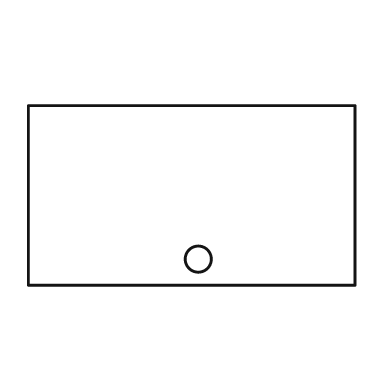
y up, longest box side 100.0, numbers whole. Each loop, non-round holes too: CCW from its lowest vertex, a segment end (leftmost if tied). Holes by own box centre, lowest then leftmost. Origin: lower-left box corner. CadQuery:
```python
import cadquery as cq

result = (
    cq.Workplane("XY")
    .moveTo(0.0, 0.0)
    .lineTo(100.0, 0.0)
    .lineTo(100.0, 55.0)
    .lineTo(0.0, 55.0)
    .close()
    .moveTo(52.0, 8.0)
    .circle(4.0)
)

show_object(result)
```